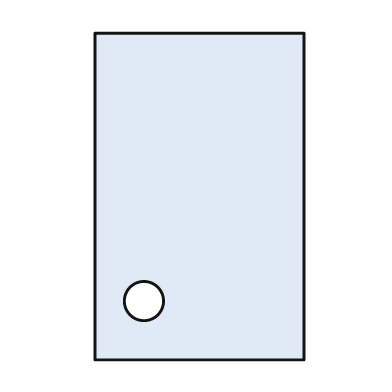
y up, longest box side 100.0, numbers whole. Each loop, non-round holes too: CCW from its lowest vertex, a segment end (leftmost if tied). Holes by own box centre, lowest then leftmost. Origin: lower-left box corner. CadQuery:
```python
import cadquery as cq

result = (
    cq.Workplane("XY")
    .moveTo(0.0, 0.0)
    .lineTo(64.0, 0.0)
    .lineTo(64.0, 100.0)
    .lineTo(0.0, 100.0)
    .close()
    .moveTo(15.0, 18.0)
    .circle(6.0)
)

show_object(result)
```